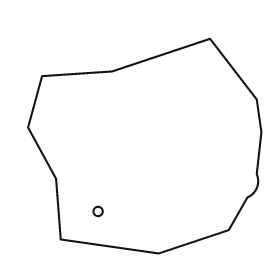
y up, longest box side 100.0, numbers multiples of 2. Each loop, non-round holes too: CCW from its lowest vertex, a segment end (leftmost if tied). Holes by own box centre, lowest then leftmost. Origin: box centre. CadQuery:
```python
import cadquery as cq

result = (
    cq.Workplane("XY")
    .moveTo(6.0, -46.0)
    .lineTo(36.0, -36.0)
    .lineTo(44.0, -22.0)
    .threePointArc((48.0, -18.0), (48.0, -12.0))
    .lineTo(50.0, 6.0)
    .lineTo(48.0, 20.0)
    .lineTo(28.0, 46.0)
    .lineTo(-14.0, 32.0)
    .lineTo(-44.0, 30.0)
    .lineTo(-50.0, 8.0)
    .lineTo(-38.0, -14.0)
    .lineTo(-36.0, -40.0)
    .close()
    .moveTo(-20.0, -28.0)
    .circle(2.0)
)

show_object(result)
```